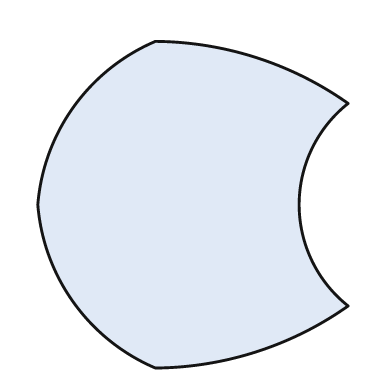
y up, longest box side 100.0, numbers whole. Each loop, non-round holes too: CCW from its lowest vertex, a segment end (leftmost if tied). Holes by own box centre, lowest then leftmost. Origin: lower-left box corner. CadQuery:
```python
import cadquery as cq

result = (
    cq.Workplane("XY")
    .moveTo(36.0, 0.0)
    .threePointArc((67.0, 5.0), (95.0, 19.0))
    .threePointArc((80.0, 50.0), (95.0, 81.0))
    .threePointArc((67.0, 95.0), (36.0, 100.0))
    .threePointArc((11.0, 80.0), (0.0, 50.0))
    .threePointArc((11.0, 20.0), (36.0, 0.0))
    .close()
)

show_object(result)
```